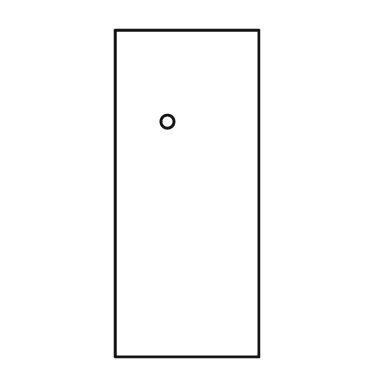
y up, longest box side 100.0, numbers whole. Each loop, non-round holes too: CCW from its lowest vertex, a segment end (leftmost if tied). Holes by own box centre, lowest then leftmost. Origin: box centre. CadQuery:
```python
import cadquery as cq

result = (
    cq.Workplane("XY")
    .moveTo(-22.0, -50.0)
    .lineTo(22.0, -50.0)
    .lineTo(22.0, 50.0)
    .lineTo(-22.0, 50.0)
    .close()
    .moveTo(-6.0, 22.0)
    .circle(2.0)
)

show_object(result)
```